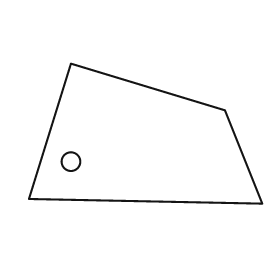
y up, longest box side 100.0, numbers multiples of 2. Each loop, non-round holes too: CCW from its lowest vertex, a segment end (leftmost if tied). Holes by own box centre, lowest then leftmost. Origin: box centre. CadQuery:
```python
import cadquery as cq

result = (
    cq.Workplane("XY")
    .moveTo(50.0, -30.0)
    .lineTo(34.0, 10.0)
    .lineTo(-32.0, 30.0)
    .lineTo(-50.0, -28.0)
    .close()
    .moveTo(-32.0, -12.0)
    .circle(4.0)
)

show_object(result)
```